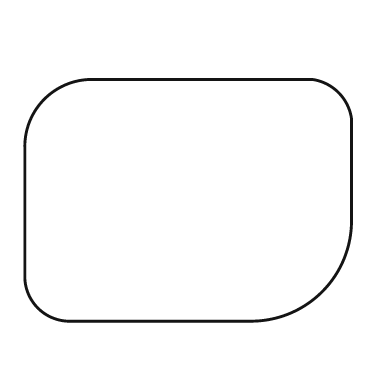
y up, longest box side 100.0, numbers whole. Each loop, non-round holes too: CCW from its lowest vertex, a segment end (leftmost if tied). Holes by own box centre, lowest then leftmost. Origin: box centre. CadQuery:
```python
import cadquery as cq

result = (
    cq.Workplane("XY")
    .moveTo(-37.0, -37.0)
    .lineTo(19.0, -37.0)
    .threePointArc((41.0, -28.0), (50.0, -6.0))
    .lineTo(50.0, 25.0)
    .threePointArc((46.0, 33.0), (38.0, 37.0))
    .lineTo(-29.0, 37.0)
    .threePointArc((-44.0, 31.0), (-50.0, 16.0))
    .lineTo(-50.0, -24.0)
    .threePointArc((-46.0, -33.0), (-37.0, -37.0))
    .close()
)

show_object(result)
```